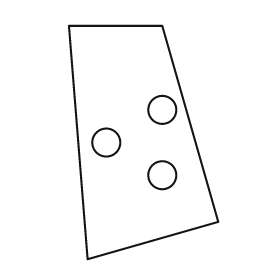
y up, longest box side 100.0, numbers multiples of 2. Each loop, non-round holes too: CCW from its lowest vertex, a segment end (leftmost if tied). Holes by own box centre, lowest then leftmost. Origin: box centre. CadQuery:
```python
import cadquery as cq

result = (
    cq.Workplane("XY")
    .moveTo(-24.0, -50.0)
    .lineTo(32.0, -34.0)
    .lineTo(8.0, 50.0)
    .lineTo(-32.0, 50.0)
    .close()
    .moveTo(8.0, -14.0)
    .circle(6.0)
    .moveTo(-16.0, 0.0)
    .circle(6.0)
    .moveTo(8.0, 14.0)
    .circle(6.0)
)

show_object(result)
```